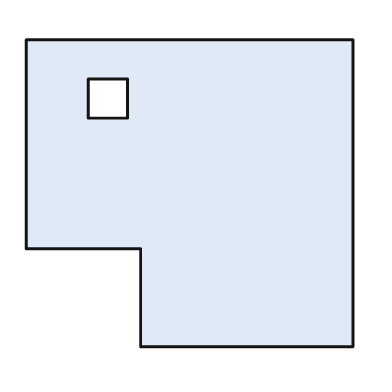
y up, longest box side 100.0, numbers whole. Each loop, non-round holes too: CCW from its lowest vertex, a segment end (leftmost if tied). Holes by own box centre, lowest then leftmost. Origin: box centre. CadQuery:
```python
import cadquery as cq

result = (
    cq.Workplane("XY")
    .moveTo(-15.0, -47.0)
    .lineTo(50.0, -47.0)
    .lineTo(50.0, 47.0)
    .lineTo(-50.0, 47.0)
    .lineTo(-50.0, -17.0)
    .lineTo(-15.0, -17.0)
    .close()
    .moveTo(-31.0, 23.0)
    .lineTo(-19.0, 23.0)
    .lineTo(-19.0, 35.0)
    .lineTo(-31.0, 35.0)
    .close()
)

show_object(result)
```